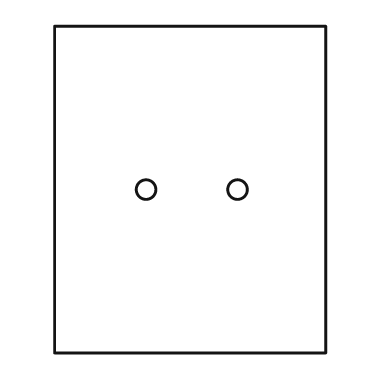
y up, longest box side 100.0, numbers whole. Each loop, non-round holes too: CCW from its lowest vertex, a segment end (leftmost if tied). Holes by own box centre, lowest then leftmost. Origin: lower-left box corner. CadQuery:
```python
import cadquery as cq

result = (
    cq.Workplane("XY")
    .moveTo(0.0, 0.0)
    .lineTo(83.0, 0.0)
    .lineTo(83.0, 100.0)
    .lineTo(0.0, 100.0)
    .close()
    .moveTo(28.0, 50.0)
    .circle(3.0)
    .moveTo(56.0, 50.0)
    .circle(3.0)
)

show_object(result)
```